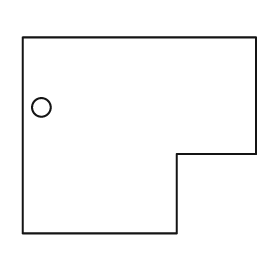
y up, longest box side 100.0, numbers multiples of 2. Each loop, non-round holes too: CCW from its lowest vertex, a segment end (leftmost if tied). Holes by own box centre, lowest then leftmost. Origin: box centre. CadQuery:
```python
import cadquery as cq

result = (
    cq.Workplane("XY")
    .moveTo(-50.0, -42.0)
    .lineTo(16.0, -42.0)
    .lineTo(16.0, -8.0)
    .lineTo(50.0, -8.0)
    .lineTo(50.0, 42.0)
    .lineTo(-50.0, 42.0)
    .close()
    .moveTo(-42.0, 12.0)
    .circle(4.0)
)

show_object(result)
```